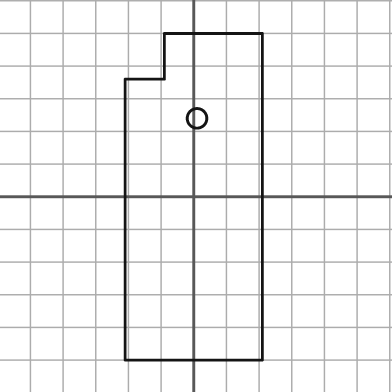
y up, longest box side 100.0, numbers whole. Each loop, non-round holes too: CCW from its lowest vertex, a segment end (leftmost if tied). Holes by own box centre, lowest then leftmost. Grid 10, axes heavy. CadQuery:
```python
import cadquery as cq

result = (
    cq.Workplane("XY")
    .moveTo(-21.0, -50.0)
    .lineTo(21.0, -50.0)
    .lineTo(21.0, 50.0)
    .lineTo(-9.0, 50.0)
    .lineTo(-9.0, 36.0)
    .lineTo(-21.0, 36.0)
    .close()
    .moveTo(1.0, 24.0)
    .circle(3.0)
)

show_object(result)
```